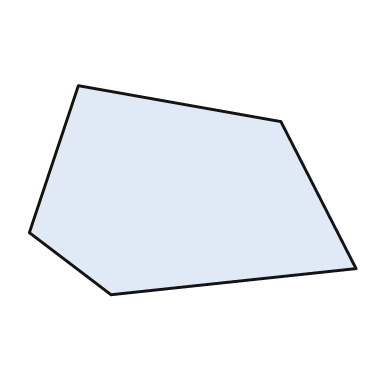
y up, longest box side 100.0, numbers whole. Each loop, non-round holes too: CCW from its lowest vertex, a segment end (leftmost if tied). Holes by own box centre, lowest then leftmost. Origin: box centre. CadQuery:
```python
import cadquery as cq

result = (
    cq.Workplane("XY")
    .moveTo(-25.0, -32.0)
    .lineTo(50.0, -24.0)
    .lineTo(27.0, 21.0)
    .lineTo(-35.0, 32.0)
    .lineTo(-50.0, -13.0)
    .close()
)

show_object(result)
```